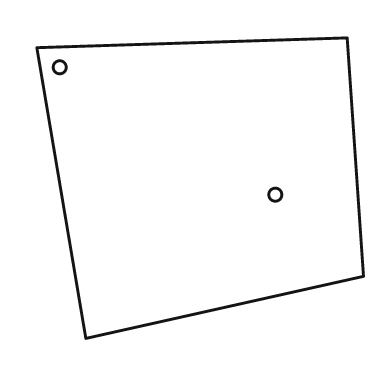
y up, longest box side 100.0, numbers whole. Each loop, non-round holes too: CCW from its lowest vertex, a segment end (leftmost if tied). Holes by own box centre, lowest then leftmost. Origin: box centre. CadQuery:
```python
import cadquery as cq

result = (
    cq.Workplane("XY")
    .moveTo(-35.0, -46.0)
    .lineTo(50.0, -27.0)
    .lineTo(45.0, 46.0)
    .lineTo(-50.0, 43.0)
    .close()
    .moveTo(23.0, -2.0)
    .circle(2.0)
    .moveTo(-43.0, 37.0)
    .circle(2.0)
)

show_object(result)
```